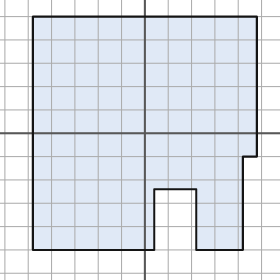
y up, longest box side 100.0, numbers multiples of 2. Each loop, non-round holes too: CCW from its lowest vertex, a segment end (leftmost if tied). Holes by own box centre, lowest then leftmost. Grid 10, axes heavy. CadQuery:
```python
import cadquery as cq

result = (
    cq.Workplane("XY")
    .moveTo(-48.0, -50.0)
    .lineTo(4.0, -50.0)
    .lineTo(4.0, -24.0)
    .lineTo(22.0, -24.0)
    .lineTo(22.0, -50.0)
    .lineTo(42.0, -50.0)
    .lineTo(42.0, -10.0)
    .lineTo(48.0, -10.0)
    .lineTo(48.0, 50.0)
    .lineTo(-48.0, 50.0)
    .close()
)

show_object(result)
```